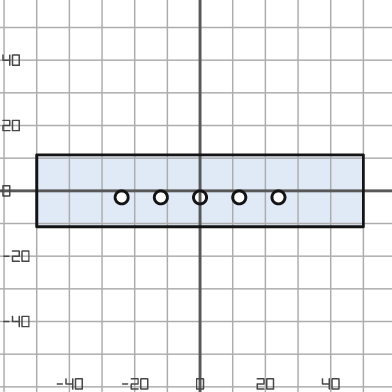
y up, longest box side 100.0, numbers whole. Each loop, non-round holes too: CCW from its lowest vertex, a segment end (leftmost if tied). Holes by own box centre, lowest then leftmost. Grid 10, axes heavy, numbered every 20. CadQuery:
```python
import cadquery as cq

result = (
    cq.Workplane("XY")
    .moveTo(-50.0, -11.0)
    .lineTo(50.0, -11.0)
    .lineTo(50.0, 11.0)
    .lineTo(-50.0, 11.0)
    .close()
    .moveTo(-24.0, -2.0)
    .circle(2.0)
    .moveTo(-12.0, -2.0)
    .circle(2.0)
    .moveTo(0.0, -2.0)
    .circle(2.0)
    .moveTo(12.0, -2.0)
    .circle(2.0)
    .moveTo(24.0, -2.0)
    .circle(2.0)
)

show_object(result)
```